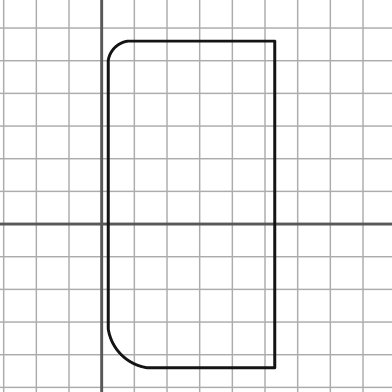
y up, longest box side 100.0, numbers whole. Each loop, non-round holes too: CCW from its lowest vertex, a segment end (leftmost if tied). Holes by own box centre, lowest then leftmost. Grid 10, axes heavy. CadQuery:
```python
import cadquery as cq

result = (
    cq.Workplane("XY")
    .moveTo(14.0, -44.0)
    .lineTo(53.0, -44.0)
    .lineTo(53.0, 56.0)
    .lineTo(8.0, 56.0)
    .threePointArc((4.0, 54.0), (2.0, 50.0))
    .lineTo(2.0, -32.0)
    .threePointArc((6.0, -40.0), (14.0, -44.0))
    .close()
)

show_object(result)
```